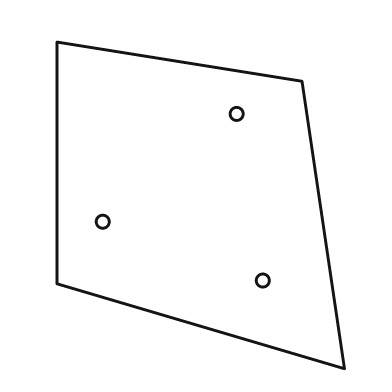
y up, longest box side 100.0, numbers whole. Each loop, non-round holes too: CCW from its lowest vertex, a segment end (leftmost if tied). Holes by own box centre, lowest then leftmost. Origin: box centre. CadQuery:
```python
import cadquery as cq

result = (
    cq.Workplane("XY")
    .moveTo(44.0, -50.0)
    .lineTo(31.0, 38.0)
    .lineTo(-44.0, 50.0)
    .lineTo(-44.0, -24.0)
    .close()
    .moveTo(19.0, -23.0)
    .circle(2.0)
    .moveTo(-30.0, -5.0)
    .circle(2.0)
    .moveTo(11.0, 28.0)
    .circle(2.0)
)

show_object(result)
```